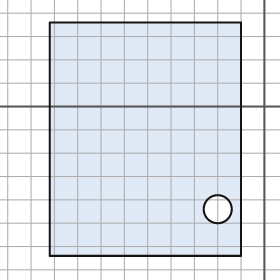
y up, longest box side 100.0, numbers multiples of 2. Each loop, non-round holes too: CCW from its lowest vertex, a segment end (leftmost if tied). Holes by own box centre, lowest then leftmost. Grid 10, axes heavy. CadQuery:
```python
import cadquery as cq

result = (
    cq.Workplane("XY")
    .moveTo(-92.0, -64.0)
    .lineTo(-10.0, -64.0)
    .lineTo(-10.0, 36.0)
    .lineTo(-92.0, 36.0)
    .close()
    .moveTo(-20.0, -44.0)
    .circle(6.0)
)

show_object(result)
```